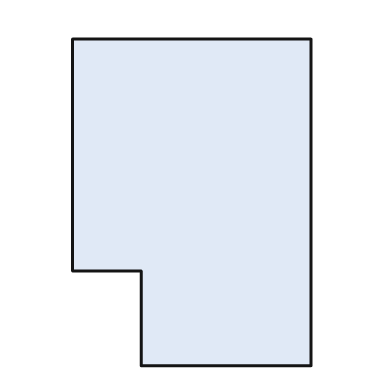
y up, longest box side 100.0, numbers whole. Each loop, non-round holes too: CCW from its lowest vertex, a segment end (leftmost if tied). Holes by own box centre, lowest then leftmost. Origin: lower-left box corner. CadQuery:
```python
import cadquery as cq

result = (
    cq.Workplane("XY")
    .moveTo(21.0, 0.0)
    .lineTo(73.0, 0.0)
    .lineTo(73.0, 100.0)
    .lineTo(0.0, 100.0)
    .lineTo(0.0, 29.0)
    .lineTo(21.0, 29.0)
    .close()
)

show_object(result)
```